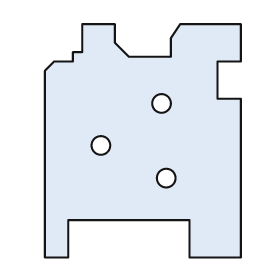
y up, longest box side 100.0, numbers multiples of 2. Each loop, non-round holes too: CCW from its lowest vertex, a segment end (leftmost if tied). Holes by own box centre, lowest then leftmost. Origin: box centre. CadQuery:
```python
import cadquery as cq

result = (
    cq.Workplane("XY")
    .moveTo(-42.0, -50.0)
    .lineTo(-32.0, -50.0)
    .lineTo(-32.0, -34.0)
    .lineTo(20.0, -34.0)
    .lineTo(20.0, -50.0)
    .lineTo(42.0, -50.0)
    .lineTo(42.0, 18.0)
    .lineTo(32.0, 18.0)
    .lineTo(32.0, 34.0)
    .lineTo(42.0, 34.0)
    .lineTo(42.0, 50.0)
    .lineTo(16.0, 50.0)
    .lineTo(12.0, 44.0)
    .lineTo(12.0, 36.0)
    .lineTo(-6.0, 36.0)
    .lineTo(-12.0, 42.0)
    .lineTo(-12.0, 50.0)
    .lineTo(-26.0, 50.0)
    .lineTo(-26.0, 38.0)
    .lineTo(-30.0, 38.0)
    .lineTo(-30.0, 34.0)
    .lineTo(-38.0, 34.0)
    .lineTo(-42.0, 30.0)
    .close()
    .moveTo(10.0, -16.0)
    .circle(4.0)
    .moveTo(-18.0, -2.0)
    .circle(4.0)
    .moveTo(8.0, 16.0)
    .circle(4.0)
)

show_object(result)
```